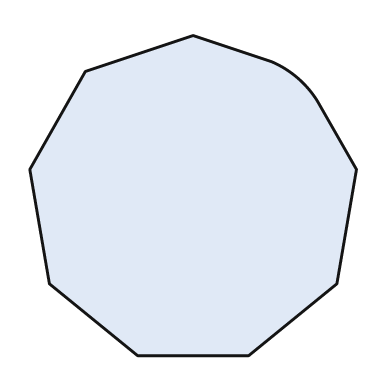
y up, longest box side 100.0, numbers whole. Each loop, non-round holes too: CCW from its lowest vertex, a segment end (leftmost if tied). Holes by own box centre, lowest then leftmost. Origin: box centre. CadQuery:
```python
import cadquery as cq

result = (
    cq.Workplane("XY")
    .moveTo(-17.0, -49.0)
    .lineTo(17.0, -49.0)
    .lineTo(44.0, -27.0)
    .lineTo(50.0, 8.0)
    .lineTo(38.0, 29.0)
    .threePointArc((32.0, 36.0), (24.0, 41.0))
    .lineTo(0.0, 49.0)
    .lineTo(-33.0, 38.0)
    .lineTo(-50.0, 8.0)
    .lineTo(-44.0, -27.0)
    .close()
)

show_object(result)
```